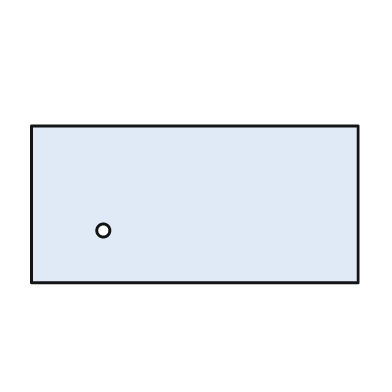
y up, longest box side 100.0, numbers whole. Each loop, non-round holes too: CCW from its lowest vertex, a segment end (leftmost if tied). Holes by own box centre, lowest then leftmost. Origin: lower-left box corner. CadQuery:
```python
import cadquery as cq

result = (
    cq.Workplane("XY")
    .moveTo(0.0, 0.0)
    .lineTo(100.0, 0.0)
    .lineTo(100.0, 48.0)
    .lineTo(0.0, 48.0)
    .close()
    .moveTo(22.0, 16.0)
    .circle(2.0)
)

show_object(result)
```